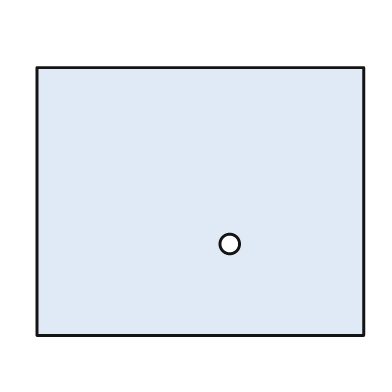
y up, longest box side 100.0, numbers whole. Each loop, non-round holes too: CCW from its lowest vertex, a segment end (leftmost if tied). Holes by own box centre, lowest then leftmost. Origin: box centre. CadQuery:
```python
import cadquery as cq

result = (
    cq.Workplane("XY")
    .moveTo(-50.0, -41.0)
    .lineTo(50.0, -41.0)
    .lineTo(50.0, 41.0)
    .lineTo(-50.0, 41.0)
    .close()
    .moveTo(9.0, -13.0)
    .circle(3.0)
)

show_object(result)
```